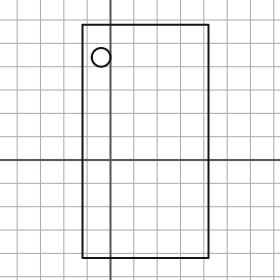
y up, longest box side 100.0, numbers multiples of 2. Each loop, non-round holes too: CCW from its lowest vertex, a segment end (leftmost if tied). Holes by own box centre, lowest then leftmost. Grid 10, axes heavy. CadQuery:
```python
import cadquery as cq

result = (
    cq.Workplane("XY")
    .moveTo(-12.0, -42.0)
    .lineTo(42.0, -42.0)
    .lineTo(42.0, 58.0)
    .lineTo(-12.0, 58.0)
    .close()
    .moveTo(-4.0, 44.0)
    .circle(4.0)
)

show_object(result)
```